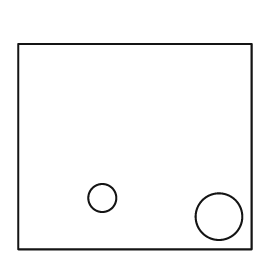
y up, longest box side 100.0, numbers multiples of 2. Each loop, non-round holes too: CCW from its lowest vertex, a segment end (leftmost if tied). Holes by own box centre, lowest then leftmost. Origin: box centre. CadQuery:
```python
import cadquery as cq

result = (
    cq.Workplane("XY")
    .moveTo(-50.0, -44.0)
    .lineTo(50.0, -44.0)
    .lineTo(50.0, 44.0)
    .lineTo(-50.0, 44.0)
    .close()
    .moveTo(36.0, -30.0)
    .circle(10.0)
    .moveTo(-14.0, -22.0)
    .circle(6.0)
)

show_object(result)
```